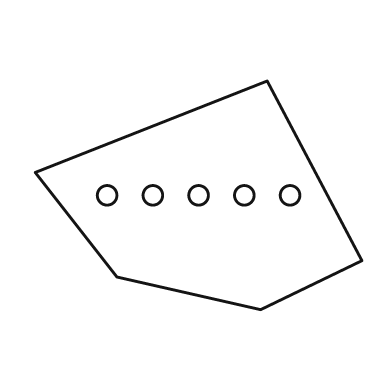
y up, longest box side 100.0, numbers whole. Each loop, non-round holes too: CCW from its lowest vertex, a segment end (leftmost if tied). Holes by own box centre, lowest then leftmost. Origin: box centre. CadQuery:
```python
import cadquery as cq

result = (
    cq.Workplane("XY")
    .moveTo(19.0, -35.0)
    .lineTo(50.0, -20.0)
    .lineTo(21.0, 35.0)
    .lineTo(-50.0, 7.0)
    .lineTo(-25.0, -25.0)
    .close()
    .moveTo(-28.0, 0.0)
    .circle(3.0)
    .moveTo(-14.0, 0.0)
    .circle(3.0)
    .moveTo(0.0, 0.0)
    .circle(3.0)
    .moveTo(14.0, 0.0)
    .circle(3.0)
    .moveTo(28.0, 0.0)
    .circle(3.0)
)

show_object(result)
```